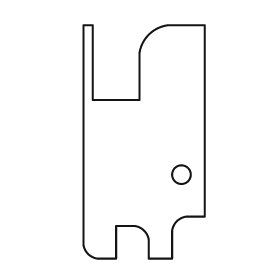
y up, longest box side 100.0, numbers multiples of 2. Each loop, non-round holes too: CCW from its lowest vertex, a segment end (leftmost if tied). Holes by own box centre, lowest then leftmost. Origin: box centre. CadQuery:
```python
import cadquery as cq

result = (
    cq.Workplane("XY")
    .moveTo(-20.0, -50.0)
    .lineTo(-12.0, -50.0)
    .lineTo(-12.0, -36.0)
    .lineTo(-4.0, -36.0)
    .threePointArc((0.0, -38.0), (2.0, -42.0))
    .lineTo(2.0, -50.0)
    .lineTo(12.0, -50.0)
    .lineTo(12.0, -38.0)
    .threePointArc((14.0, -34.0), (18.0, -32.0))
    .lineTo(26.0, -32.0)
    .lineTo(26.0, 50.0)
    .lineTo(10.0, 50.0)
    .threePointArc((2.0, 46.0), (-2.0, 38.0))
    .lineTo(-2.0, 18.0)
    .lineTo(-22.0, 18.0)
    .lineTo(-22.0, 50.0)
    .lineTo(-26.0, 50.0)
    .lineTo(-26.0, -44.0)
    .threePointArc((-24.0, -48.0), (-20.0, -50.0))
    .close()
    .moveTo(16.0, -14.0)
    .circle(4.0)
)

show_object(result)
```